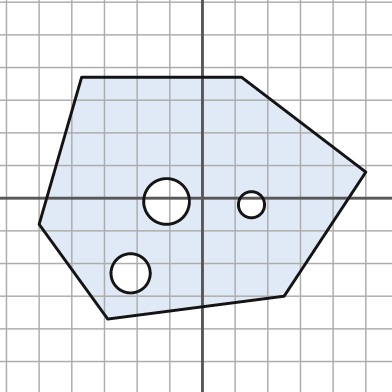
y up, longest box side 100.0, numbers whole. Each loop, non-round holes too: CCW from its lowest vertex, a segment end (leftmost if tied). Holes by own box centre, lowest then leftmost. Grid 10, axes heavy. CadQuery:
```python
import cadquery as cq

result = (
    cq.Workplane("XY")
    .moveTo(-29.0, -37.0)
    .lineTo(25.0, -30.0)
    .lineTo(50.0, 8.0)
    .lineTo(12.0, 37.0)
    .lineTo(-37.0, 37.0)
    .lineTo(-50.0, -8.0)
    .close()
    .moveTo(-22.0, -23.0)
    .circle(6.0)
    .moveTo(15.0, -2.0)
    .circle(4.0)
    .moveTo(-11.0, -1.0)
    .circle(7.0)
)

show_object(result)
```